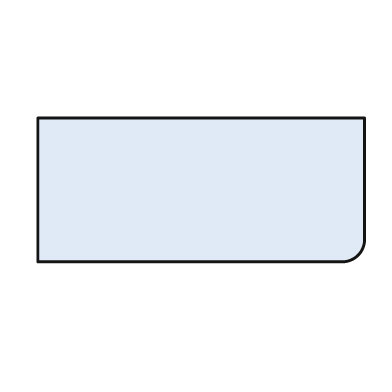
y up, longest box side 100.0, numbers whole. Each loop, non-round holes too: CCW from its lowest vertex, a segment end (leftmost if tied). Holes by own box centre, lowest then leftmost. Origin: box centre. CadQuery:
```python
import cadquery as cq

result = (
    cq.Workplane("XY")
    .moveTo(-50.0, -22.0)
    .lineTo(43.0, -22.0)
    .threePointArc((48.0, -20.0), (50.0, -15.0))
    .lineTo(50.0, 22.0)
    .lineTo(-50.0, 22.0)
    .close()
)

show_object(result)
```